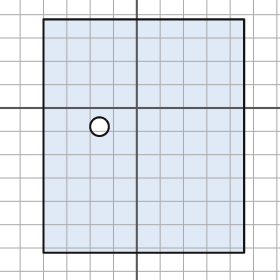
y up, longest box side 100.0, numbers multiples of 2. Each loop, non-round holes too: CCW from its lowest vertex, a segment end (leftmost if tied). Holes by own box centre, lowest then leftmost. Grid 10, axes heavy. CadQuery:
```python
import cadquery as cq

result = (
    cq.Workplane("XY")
    .moveTo(-40.0, -62.0)
    .lineTo(46.0, -62.0)
    .lineTo(46.0, 38.0)
    .lineTo(-40.0, 38.0)
    .close()
    .moveTo(-16.0, -8.0)
    .circle(4.0)
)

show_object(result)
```